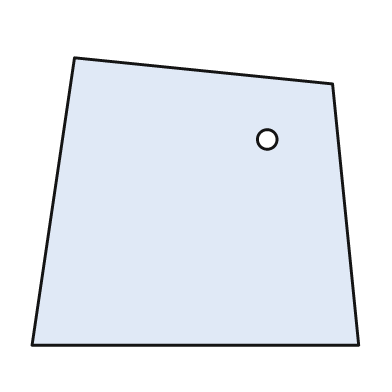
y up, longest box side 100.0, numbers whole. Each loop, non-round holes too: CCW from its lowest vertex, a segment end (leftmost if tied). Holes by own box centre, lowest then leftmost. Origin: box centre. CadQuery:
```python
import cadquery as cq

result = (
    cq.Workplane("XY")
    .moveTo(-50.0, -44.0)
    .lineTo(50.0, -44.0)
    .lineTo(42.0, 36.0)
    .lineTo(-37.0, 44.0)
    .close()
    .moveTo(22.0, 19.0)
    .circle(3.0)
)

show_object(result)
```